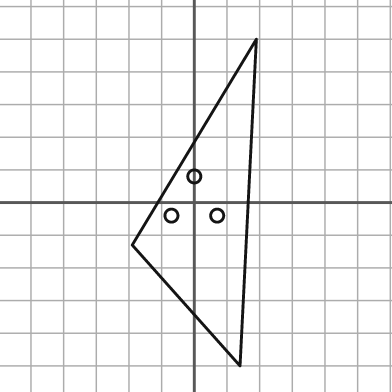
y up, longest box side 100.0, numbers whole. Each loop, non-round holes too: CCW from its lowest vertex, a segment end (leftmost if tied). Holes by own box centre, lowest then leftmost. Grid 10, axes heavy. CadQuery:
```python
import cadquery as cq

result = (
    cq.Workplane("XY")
    .moveTo(14.0, -50.0)
    .lineTo(19.0, 50.0)
    .lineTo(-19.0, -13.0)
    .close()
    .moveTo(-7.0, -4.0)
    .circle(2.0)
    .moveTo(7.0, -4.0)
    .circle(2.0)
    .moveTo(0.0, 8.0)
    .circle(2.0)
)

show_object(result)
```